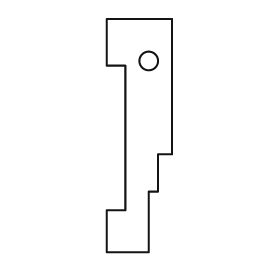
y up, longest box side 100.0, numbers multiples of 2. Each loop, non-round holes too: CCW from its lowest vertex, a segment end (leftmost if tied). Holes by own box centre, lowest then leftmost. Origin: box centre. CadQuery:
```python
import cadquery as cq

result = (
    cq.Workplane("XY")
    .moveTo(-14.0, -50.0)
    .lineTo(4.0, -50.0)
    .lineTo(4.0, -24.0)
    .lineTo(8.0, -24.0)
    .lineTo(8.0, -8.0)
    .lineTo(14.0, -8.0)
    .lineTo(14.0, 50.0)
    .lineTo(-14.0, 50.0)
    .lineTo(-14.0, 30.0)
    .lineTo(-6.0, 30.0)
    .lineTo(-6.0, -32.0)
    .lineTo(-14.0, -32.0)
    .close()
    .moveTo(4.0, 32.0)
    .circle(4.0)
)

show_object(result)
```